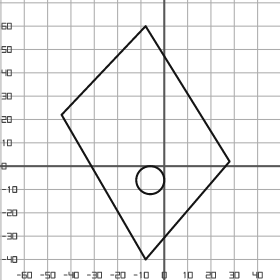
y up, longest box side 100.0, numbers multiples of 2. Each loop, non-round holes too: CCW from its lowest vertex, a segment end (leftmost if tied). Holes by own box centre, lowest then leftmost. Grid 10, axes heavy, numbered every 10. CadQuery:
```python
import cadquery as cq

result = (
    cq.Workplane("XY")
    .moveTo(-8.0, -40.0)
    .lineTo(28.0, 2.0)
    .lineTo(-8.0, 60.0)
    .lineTo(-44.0, 22.0)
    .close()
    .moveTo(-6.0, -6.0)
    .circle(6.0)
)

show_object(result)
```